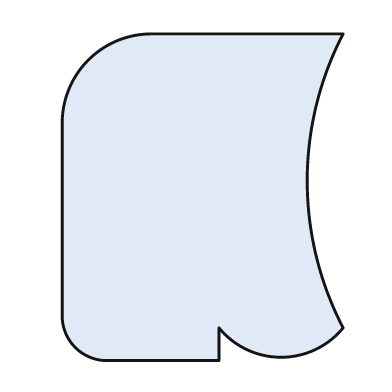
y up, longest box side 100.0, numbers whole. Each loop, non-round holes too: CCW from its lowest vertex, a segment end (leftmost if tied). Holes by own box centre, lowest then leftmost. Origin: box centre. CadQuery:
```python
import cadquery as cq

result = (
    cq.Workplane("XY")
    .moveTo(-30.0, -50.0)
    .lineTo(5.0, -50.0)
    .lineTo(5.0, -40.0)
    .threePointArc((24.0, -49.0), (43.0, -40.0))
    .threePointArc((32.0, 5.0), (43.0, 50.0))
    .lineTo(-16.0, 50.0)
    .threePointArc((-35.0, 42.0), (-43.0, 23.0))
    .lineTo(-43.0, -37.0)
    .threePointArc((-39.0, -46.0), (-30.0, -50.0))
    .close()
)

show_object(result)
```